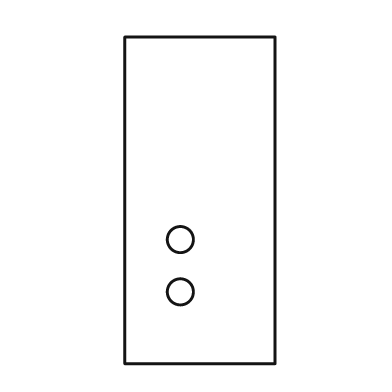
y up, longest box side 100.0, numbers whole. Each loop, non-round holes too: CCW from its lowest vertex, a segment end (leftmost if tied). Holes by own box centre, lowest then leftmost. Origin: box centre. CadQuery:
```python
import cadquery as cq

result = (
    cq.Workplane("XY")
    .moveTo(-23.0, -50.0)
    .lineTo(23.0, -50.0)
    .lineTo(23.0, 50.0)
    .lineTo(-23.0, 50.0)
    .close()
    .moveTo(-6.0, -28.0)
    .circle(4.0)
    .moveTo(-6.0, -12.0)
    .circle(4.0)
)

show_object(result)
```